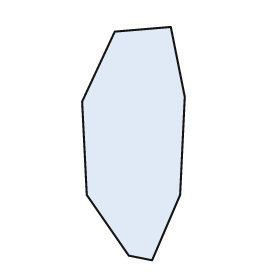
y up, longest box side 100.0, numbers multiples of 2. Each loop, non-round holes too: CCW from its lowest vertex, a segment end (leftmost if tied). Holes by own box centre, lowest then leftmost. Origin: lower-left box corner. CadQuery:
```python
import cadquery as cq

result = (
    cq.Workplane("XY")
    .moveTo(30.0, 0.0)
    .lineTo(42.0, 28.0)
    .lineTo(44.0, 70.0)
    .lineTo(38.0, 100.0)
    .lineTo(14.0, 98.0)
    .lineTo(0.0, 68.0)
    .lineTo(2.0, 28.0)
    .lineTo(20.0, 2.0)
    .close()
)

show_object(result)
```